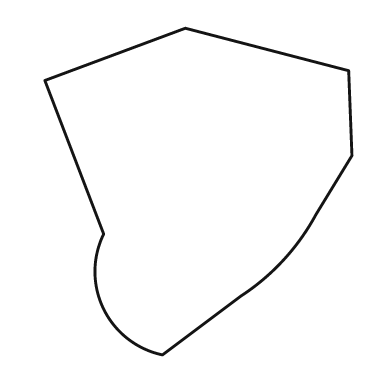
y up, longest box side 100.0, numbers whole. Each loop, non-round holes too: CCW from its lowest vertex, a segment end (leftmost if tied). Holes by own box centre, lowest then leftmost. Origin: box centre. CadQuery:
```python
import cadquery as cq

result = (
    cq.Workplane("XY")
    .moveTo(-11.0, -50.0)
    .lineTo(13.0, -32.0)
    .threePointArc((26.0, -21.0), (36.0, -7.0))
    .lineTo(47.0, 11.0)
    .lineTo(46.0, 37.0)
    .lineTo(-4.0, 50.0)
    .lineTo(-47.0, 34.0)
    .lineTo(-29.0, -13.0)
    .threePointArc((-29.0, -36.0), (-11.0, -50.0))
    .close()
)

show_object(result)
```